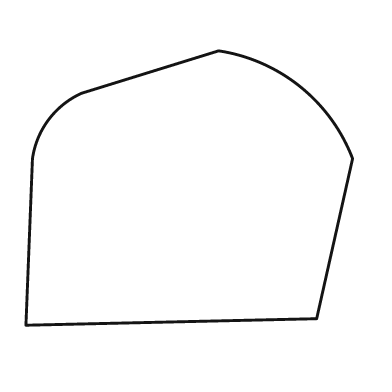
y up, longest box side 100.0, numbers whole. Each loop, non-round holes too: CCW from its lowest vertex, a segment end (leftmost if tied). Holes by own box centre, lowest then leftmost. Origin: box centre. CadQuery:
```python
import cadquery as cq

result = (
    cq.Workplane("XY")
    .moveTo(-50.0, -42.0)
    .lineTo(39.0, -40.0)
    .lineTo(50.0, 9.0)
    .threePointArc((34.0, 31.0), (9.0, 42.0))
    .lineTo(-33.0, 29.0)
    .threePointArc((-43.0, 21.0), (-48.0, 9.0))
    .close()
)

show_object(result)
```